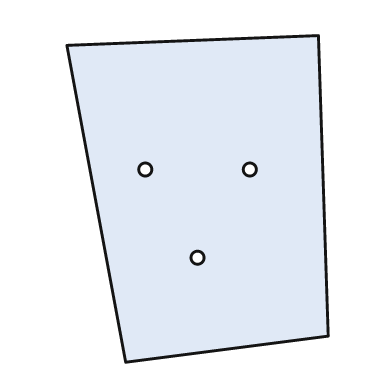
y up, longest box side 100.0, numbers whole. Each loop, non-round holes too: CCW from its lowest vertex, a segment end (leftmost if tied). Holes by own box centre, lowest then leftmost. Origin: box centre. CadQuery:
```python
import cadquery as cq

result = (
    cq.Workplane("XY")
    .moveTo(-22.0, -50.0)
    .lineTo(40.0, -42.0)
    .lineTo(37.0, 50.0)
    .lineTo(-40.0, 47.0)
    .close()
    .moveTo(0.0, -18.0)
    .circle(2.0)
    .moveTo(-16.0, 9.0)
    .circle(2.0)
    .moveTo(16.0, 9.0)
    .circle(2.0)
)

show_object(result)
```